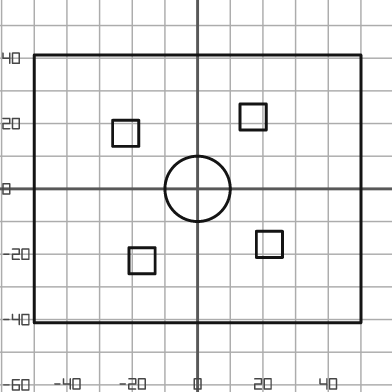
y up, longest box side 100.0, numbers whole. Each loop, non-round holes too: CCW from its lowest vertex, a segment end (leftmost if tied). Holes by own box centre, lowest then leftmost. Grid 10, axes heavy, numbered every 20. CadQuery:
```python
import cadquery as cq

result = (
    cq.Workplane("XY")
    .moveTo(-50.0, -41.0)
    .lineTo(50.0, -41.0)
    .lineTo(50.0, 41.0)
    .lineTo(-50.0, 41.0)
    .close()
    .moveTo(-21.0, -26.0)
    .lineTo(-13.0, -26.0)
    .lineTo(-13.0, -18.0)
    .lineTo(-21.0, -18.0)
    .close()
    .moveTo(18.0, -21.0)
    .lineTo(26.0, -21.0)
    .lineTo(26.0, -13.0)
    .lineTo(18.0, -13.0)
    .close()
    .moveTo(0.0, 0.0)
    .circle(10.0)
    .moveTo(-26.0, 13.0)
    .lineTo(-18.0, 13.0)
    .lineTo(-18.0, 21.0)
    .lineTo(-26.0, 21.0)
    .close()
    .moveTo(13.0, 18.0)
    .lineTo(21.0, 18.0)
    .lineTo(21.0, 26.0)
    .lineTo(13.0, 26.0)
    .close()
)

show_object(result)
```